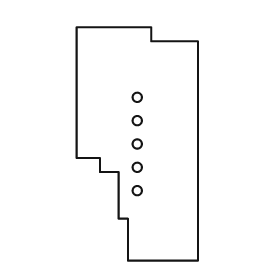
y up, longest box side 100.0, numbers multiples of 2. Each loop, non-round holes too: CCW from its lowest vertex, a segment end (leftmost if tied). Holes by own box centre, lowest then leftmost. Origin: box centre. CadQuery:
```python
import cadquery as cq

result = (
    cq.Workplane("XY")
    .moveTo(-4.0, -50.0)
    .lineTo(26.0, -50.0)
    .lineTo(26.0, 44.0)
    .lineTo(6.0, 44.0)
    .lineTo(6.0, 50.0)
    .lineTo(-26.0, 50.0)
    .lineTo(-26.0, -6.0)
    .lineTo(-16.0, -6.0)
    .lineTo(-16.0, -12.0)
    .lineTo(-8.0, -12.0)
    .lineTo(-8.0, -32.0)
    .lineTo(-4.0, -32.0)
    .close()
    .moveTo(0.0, -20.0)
    .circle(2.0)
    .moveTo(0.0, -10.0)
    .circle(2.0)
    .moveTo(0.0, 0.0)
    .circle(2.0)
    .moveTo(0.0, 10.0)
    .circle(2.0)
    .moveTo(0.0, 20.0)
    .circle(2.0)
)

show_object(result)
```